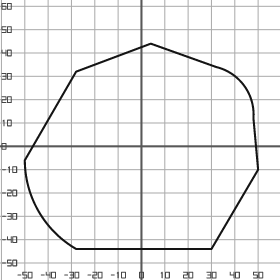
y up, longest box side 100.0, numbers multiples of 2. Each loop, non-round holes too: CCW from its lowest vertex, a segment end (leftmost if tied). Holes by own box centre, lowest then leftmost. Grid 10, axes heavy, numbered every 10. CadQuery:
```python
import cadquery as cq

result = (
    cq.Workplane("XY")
    .moveTo(-28.0, -44.0)
    .lineTo(30.0, -44.0)
    .lineTo(50.0, -10.0)
    .lineTo(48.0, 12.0)
    .threePointArc((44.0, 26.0), (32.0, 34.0))
    .lineTo(4.0, 44.0)
    .lineTo(-28.0, 32.0)
    .lineTo(-50.0, -6.0)
    .threePointArc((-44.0, -28.0), (-28.0, -44.0))
    .close()
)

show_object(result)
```